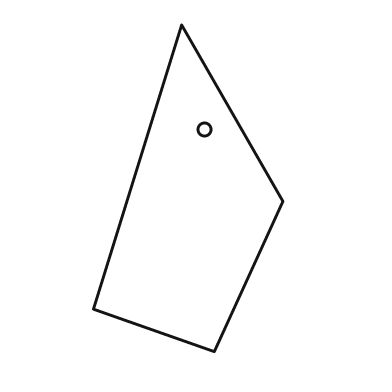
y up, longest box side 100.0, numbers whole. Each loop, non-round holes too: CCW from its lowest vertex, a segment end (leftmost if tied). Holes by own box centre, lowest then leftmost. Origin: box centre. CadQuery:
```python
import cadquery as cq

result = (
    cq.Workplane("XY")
    .moveTo(8.0, -50.0)
    .lineTo(29.0, -4.0)
    .lineTo(-2.0, 50.0)
    .lineTo(-29.0, -37.0)
    .close()
    .moveTo(5.0, 18.0)
    .circle(2.0)
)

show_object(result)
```